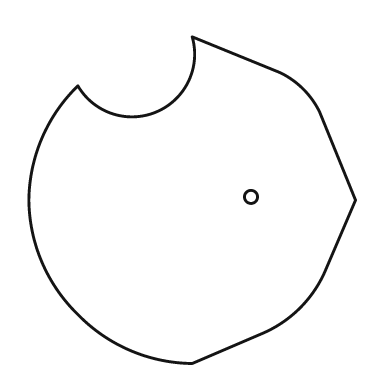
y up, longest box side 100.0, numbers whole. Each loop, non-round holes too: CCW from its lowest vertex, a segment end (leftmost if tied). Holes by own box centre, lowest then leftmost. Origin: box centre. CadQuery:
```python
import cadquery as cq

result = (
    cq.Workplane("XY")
    .moveTo(0.0, -50.0)
    .lineTo(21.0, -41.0)
    .threePointArc((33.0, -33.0), (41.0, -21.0))
    .lineTo(50.0, 0.0)
    .lineTo(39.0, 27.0)
    .threePointArc((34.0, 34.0), (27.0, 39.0))
    .lineTo(0.0, 50.0)
    .threePointArc((-11.0, 27.0), (-35.0, 35.0))
    .threePointArc((-46.0, 19.0), (-50.0, 0.0))
    .threePointArc((-46.0, -19.0), (-35.0, -35.0))
    .threePointArc((-19.0, -46.0), (0.0, -50.0))
    .close()
    .moveTo(18.0, 1.0)
    .circle(2.0)
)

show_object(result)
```